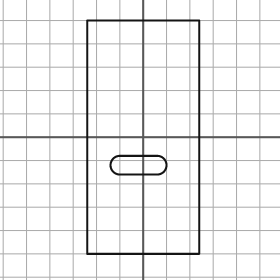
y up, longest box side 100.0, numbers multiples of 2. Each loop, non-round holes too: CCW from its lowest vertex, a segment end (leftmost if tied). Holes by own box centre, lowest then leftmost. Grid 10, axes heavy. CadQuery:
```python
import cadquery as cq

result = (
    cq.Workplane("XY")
    .moveTo(-24.0, -50.0)
    .lineTo(24.0, -50.0)
    .lineTo(24.0, 50.0)
    .lineTo(-24.0, 50.0)
    .close()
    .moveTo(-10.0, -16.0)
    .lineTo(6.0, -16.0)
    .threePointArc((10.0, -12.0), (6.0, -8.0))
    .lineTo(-10.0, -8.0)
    .threePointArc((-14.0, -12.0), (-10.0, -16.0))
    .close()
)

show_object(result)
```